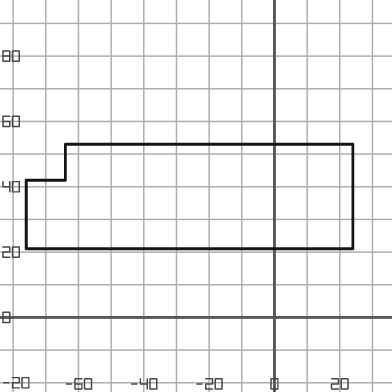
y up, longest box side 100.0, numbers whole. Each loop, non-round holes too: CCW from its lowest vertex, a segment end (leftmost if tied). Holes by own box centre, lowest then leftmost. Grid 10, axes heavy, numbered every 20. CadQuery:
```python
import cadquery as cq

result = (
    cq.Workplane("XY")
    .moveTo(-76.0, 21.0)
    .lineTo(24.0, 21.0)
    .lineTo(24.0, 53.0)
    .lineTo(-64.0, 53.0)
    .lineTo(-64.0, 42.0)
    .lineTo(-76.0, 42.0)
    .close()
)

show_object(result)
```